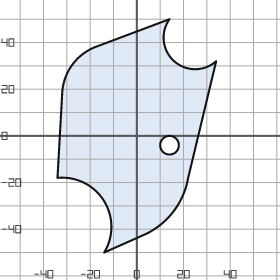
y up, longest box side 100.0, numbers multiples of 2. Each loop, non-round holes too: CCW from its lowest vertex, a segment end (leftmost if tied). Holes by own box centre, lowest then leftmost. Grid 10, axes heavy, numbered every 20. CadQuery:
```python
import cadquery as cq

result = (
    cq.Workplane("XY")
    .moveTo(-14.0, -50.0)
    .lineTo(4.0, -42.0)
    .threePointArc((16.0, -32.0), (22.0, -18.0))
    .lineTo(34.0, 32.0)
    .threePointArc((16.0, 32.0), (14.0, 50.0))
    .lineTo(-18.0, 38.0)
    .threePointArc((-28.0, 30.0), (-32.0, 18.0))
    .lineTo(-34.0, -18.0)
    .threePointArc((-14.0, -28.0), (-14.0, -50.0))
    .close()
    .moveTo(14.0, -4.0)
    .circle(4.0)
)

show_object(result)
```